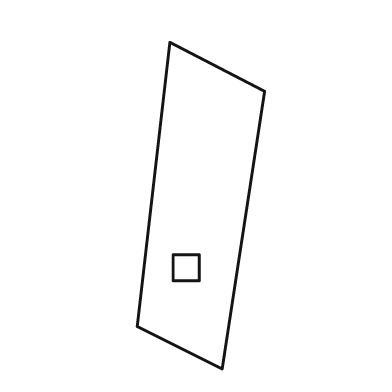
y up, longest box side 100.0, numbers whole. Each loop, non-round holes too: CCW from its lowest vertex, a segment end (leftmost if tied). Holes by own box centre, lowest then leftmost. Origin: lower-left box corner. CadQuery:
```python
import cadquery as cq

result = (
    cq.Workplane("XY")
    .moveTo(26.0, 0.0)
    .lineTo(39.0, 85.0)
    .lineTo(10.0, 100.0)
    .lineTo(0.0, 13.0)
    .close()
    .moveTo(11.0, 27.0)
    .lineTo(19.0, 27.0)
    .lineTo(19.0, 35.0)
    .lineTo(11.0, 35.0)
    .close()
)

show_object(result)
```